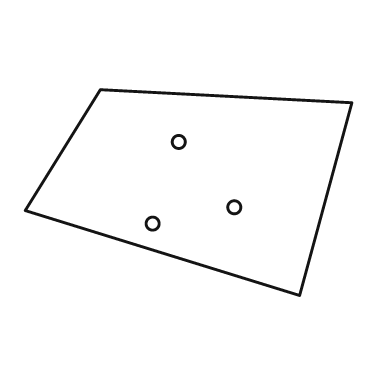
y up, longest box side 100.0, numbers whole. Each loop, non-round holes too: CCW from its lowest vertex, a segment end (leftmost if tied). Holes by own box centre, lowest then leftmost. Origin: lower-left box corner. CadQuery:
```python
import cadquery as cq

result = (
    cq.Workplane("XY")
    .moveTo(84.0, 0.0)
    .lineTo(100.0, 59.0)
    .lineTo(23.0, 63.0)
    .lineTo(0.0, 26.0)
    .close()
    .moveTo(39.0, 22.0)
    .circle(2.0)
    .moveTo(64.0, 27.0)
    .circle(2.0)
    .moveTo(47.0, 47.0)
    .circle(2.0)
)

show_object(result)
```